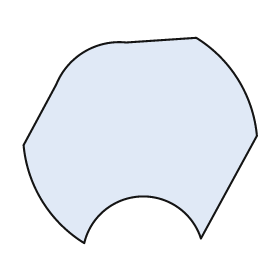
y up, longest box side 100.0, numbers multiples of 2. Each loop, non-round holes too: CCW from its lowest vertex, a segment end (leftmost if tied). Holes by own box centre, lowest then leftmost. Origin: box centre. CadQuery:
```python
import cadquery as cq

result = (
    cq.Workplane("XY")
    .moveTo(-24.0, -44.0)
    .threePointArc((0.0, -24.0), (26.0, -42.0))
    .lineTo(50.0, 2.0)
    .threePointArc((42.0, 26.0), (24.0, 44.0))
    .lineTo(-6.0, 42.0)
    .threePointArc((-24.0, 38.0), (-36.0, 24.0))
    .lineTo(-50.0, -2.0)
    .threePointArc((-42.0, -26.0), (-24.0, -44.0))
    .close()
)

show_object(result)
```